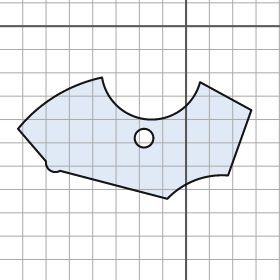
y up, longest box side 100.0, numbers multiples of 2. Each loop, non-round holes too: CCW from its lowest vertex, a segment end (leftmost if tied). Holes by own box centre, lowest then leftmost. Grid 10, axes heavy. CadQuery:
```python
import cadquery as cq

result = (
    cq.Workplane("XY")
    .moveTo(-8.0, -74.0)
    .threePointArc((4.0, -66.0), (18.0, -64.0))
    .lineTo(28.0, -36.0)
    .lineTo(6.0, -24.0)
    .threePointArc((-16.0, -40.0), (-36.0, -22.0))
    .threePointArc((-56.0, -30.0), (-72.0, -44.0))
    .lineTo(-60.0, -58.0)
    .threePointArc((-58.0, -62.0), (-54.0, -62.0))
    .close()
    .moveTo(-18.0, -48.0)
    .circle(4.0)
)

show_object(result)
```